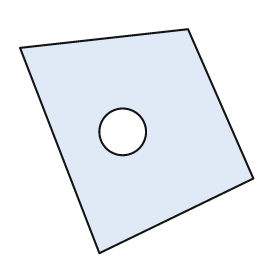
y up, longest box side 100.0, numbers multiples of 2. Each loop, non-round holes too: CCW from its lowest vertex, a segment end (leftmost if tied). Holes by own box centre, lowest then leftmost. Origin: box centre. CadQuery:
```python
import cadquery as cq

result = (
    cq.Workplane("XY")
    .moveTo(-16.0, -48.0)
    .lineTo(50.0, -16.0)
    .lineTo(22.0, 48.0)
    .lineTo(-50.0, 40.0)
    .close()
    .moveTo(-6.0, 4.0)
    .circle(10.0)
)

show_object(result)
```